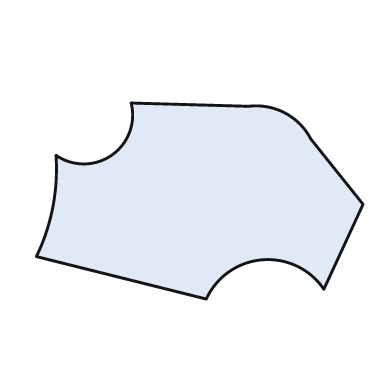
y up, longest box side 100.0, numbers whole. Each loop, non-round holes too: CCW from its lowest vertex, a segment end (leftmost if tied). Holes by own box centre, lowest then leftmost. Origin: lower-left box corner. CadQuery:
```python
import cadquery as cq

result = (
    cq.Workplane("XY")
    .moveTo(52.0, 0.0)
    .threePointArc((69.0, 12.0), (88.0, 3.0))
    .lineTo(100.0, 29.0)
    .lineTo(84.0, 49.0)
    .threePointArc((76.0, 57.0), (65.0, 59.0))
    .lineTo(29.0, 60.0)
    .threePointArc((23.0, 44.0), (6.0, 44.0))
    .threePointArc((5.0, 28.0), (0.0, 13.0))
    .close()
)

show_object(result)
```